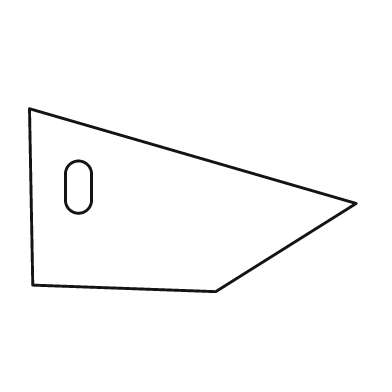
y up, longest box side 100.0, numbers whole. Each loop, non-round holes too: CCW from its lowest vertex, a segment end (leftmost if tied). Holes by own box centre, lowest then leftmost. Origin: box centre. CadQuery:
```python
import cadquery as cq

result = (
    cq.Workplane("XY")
    .moveTo(7.0, -28.0)
    .lineTo(50.0, -1.0)
    .lineTo(-50.0, 28.0)
    .lineTo(-49.0, -26.0)
    .close()
    .moveTo(-39.0, 0.0)
    .threePointArc((-35.0, -4.0), (-31.0, 0.0))
    .lineTo(-31.0, 8.0)
    .threePointArc((-35.0, 12.0), (-39.0, 8.0))
    .close()
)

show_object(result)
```